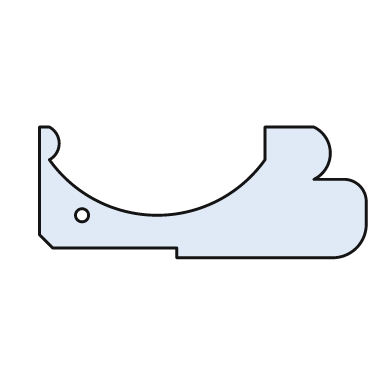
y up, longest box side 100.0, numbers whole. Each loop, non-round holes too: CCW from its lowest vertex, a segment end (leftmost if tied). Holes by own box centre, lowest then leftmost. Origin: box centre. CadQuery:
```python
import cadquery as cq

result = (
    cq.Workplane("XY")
    .moveTo(-8.0, -20.0)
    .lineTo(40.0, -20.0)
    .threePointArc((47.0, -17.0), (50.0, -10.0))
    .lineTo(50.0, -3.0)
    .threePointArc((48.0, 2.0), (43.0, 4.0))
    .lineTo(34.0, 4.0)
    .threePointArc((39.0, 12.0), (34.0, 20.0))
    .lineTo(19.0, 20.0)
    .lineTo(19.0, 10.0)
    .threePointArc((-14.0, -7.0), (-47.0, 10.0))
    .threePointArc((-44.0, 15.0), (-47.0, 20.0))
    .lineTo(-50.0, 20.0)
    .lineTo(-50.0, -13.0)
    .lineTo(-46.0, -17.0)
    .lineTo(-8.0, -17.0)
    .close()
    .moveTo(-37.0, -7.0)
    .circle(2.0)
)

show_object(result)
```